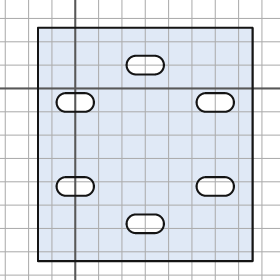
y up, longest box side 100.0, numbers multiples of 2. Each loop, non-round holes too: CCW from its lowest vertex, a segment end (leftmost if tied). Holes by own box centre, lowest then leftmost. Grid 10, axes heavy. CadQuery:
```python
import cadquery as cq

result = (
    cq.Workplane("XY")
    .moveTo(-16.0, -74.0)
    .lineTo(76.0, -74.0)
    .lineTo(76.0, 26.0)
    .lineTo(-16.0, 26.0)
    .close()
    .moveTo(26.0, -62.0)
    .lineTo(34.0, -62.0)
    .threePointArc((38.0, -58.0), (34.0, -54.0))
    .lineTo(26.0, -54.0)
    .threePointArc((22.0, -58.0), (26.0, -62.0))
    .close()
    .moveTo(-4.0, -46.0)
    .lineTo(4.0, -46.0)
    .threePointArc((8.0, -42.0), (4.0, -38.0))
    .lineTo(-4.0, -38.0)
    .threePointArc((-8.0, -42.0), (-4.0, -46.0))
    .close()
    .moveTo(56.0, -46.0)
    .lineTo(64.0, -46.0)
    .threePointArc((68.0, -42.0), (64.0, -38.0))
    .lineTo(56.0, -38.0)
    .threePointArc((52.0, -42.0), (56.0, -46.0))
    .close()
    .moveTo(-4.0, -10.0)
    .lineTo(4.0, -10.0)
    .threePointArc((8.0, -6.0), (4.0, -2.0))
    .lineTo(-4.0, -2.0)
    .threePointArc((-8.0, -6.0), (-4.0, -10.0))
    .close()
    .moveTo(56.0, -10.0)
    .lineTo(64.0, -10.0)
    .threePointArc((68.0, -6.0), (64.0, -2.0))
    .lineTo(56.0, -2.0)
    .threePointArc((52.0, -6.0), (56.0, -10.0))
    .close()
    .moveTo(26.0, 6.0)
    .lineTo(34.0, 6.0)
    .threePointArc((38.0, 10.0), (34.0, 14.0))
    .lineTo(26.0, 14.0)
    .threePointArc((22.0, 10.0), (26.0, 6.0))
    .close()
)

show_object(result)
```